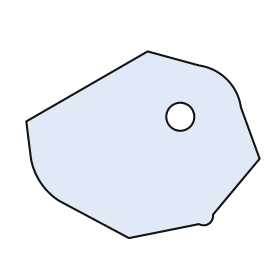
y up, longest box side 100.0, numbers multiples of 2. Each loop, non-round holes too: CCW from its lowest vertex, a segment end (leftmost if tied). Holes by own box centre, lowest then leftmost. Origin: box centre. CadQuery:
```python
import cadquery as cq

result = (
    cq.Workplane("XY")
    .moveTo(-6.0, -40.0)
    .lineTo(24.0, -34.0)
    .threePointArc((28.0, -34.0), (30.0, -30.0))
    .lineTo(50.0, -6.0)
    .lineTo(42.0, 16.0)
    .threePointArc((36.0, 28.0), (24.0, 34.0))
    .lineTo(2.0, 40.0)
    .lineTo(-50.0, 10.0)
    .lineTo(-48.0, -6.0)
    .threePointArc((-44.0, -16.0), (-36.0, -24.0))
    .close()
    .moveTo(16.0, 12.0)
    .circle(6.0)
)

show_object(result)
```